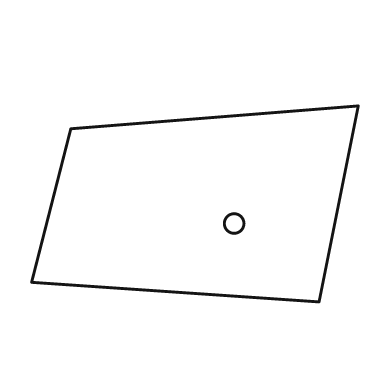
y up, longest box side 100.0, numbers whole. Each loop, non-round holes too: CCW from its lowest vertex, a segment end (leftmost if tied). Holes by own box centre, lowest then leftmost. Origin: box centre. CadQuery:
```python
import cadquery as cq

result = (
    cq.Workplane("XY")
    .moveTo(38.0, -30.0)
    .lineTo(50.0, 30.0)
    .lineTo(-38.0, 23.0)
    .lineTo(-50.0, -24.0)
    .close()
    .moveTo(12.0, -6.0)
    .circle(3.0)
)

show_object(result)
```